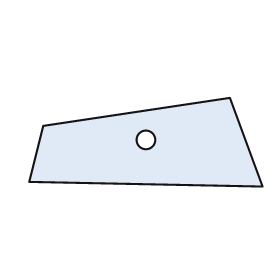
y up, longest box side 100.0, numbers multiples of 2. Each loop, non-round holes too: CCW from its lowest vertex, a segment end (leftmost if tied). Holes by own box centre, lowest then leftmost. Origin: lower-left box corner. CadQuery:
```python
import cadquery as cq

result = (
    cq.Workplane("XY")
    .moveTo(100.0, 0.0)
    .lineTo(86.0, 38.0)
    .lineTo(6.0, 26.0)
    .lineTo(0.0, 2.0)
    .close()
    .moveTo(50.0, 20.0)
    .circle(4.0)
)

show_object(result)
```